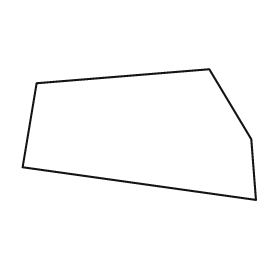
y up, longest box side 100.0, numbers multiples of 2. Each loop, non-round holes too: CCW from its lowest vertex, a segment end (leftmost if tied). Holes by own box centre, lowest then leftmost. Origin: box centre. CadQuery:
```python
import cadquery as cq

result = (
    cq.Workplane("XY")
    .moveTo(50.0, -28.0)
    .lineTo(48.0, -2.0)
    .lineTo(30.0, 28.0)
    .lineTo(-44.0, 22.0)
    .lineTo(-50.0, -14.0)
    .close()
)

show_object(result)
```